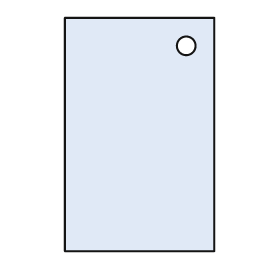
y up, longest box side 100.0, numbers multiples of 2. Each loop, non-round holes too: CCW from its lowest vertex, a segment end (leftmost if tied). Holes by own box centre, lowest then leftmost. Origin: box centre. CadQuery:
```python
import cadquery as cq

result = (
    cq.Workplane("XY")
    .moveTo(-32.0, -50.0)
    .lineTo(32.0, -50.0)
    .lineTo(32.0, 50.0)
    .lineTo(-32.0, 50.0)
    .close()
    .moveTo(20.0, 38.0)
    .circle(4.0)
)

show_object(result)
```